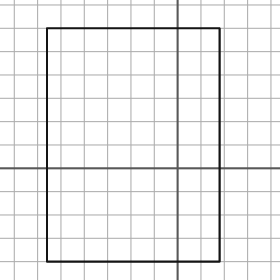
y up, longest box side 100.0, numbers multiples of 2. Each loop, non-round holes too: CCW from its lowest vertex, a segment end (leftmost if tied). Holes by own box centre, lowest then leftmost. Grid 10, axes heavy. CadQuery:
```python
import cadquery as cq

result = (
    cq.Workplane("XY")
    .moveTo(-56.0, -40.0)
    .lineTo(18.0, -40.0)
    .lineTo(18.0, 60.0)
    .lineTo(-56.0, 60.0)
    .close()
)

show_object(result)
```